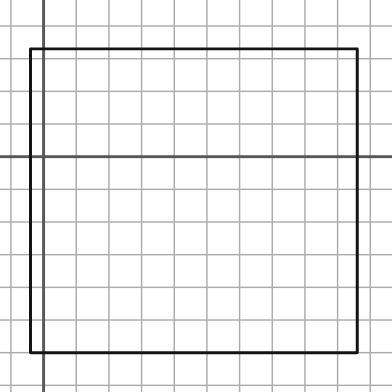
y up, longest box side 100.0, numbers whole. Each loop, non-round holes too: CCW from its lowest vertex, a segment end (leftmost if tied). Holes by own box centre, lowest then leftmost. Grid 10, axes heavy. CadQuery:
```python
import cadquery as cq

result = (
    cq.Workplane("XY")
    .moveTo(-4.0, -60.0)
    .lineTo(96.0, -60.0)
    .lineTo(96.0, 33.0)
    .lineTo(-4.0, 33.0)
    .close()
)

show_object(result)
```